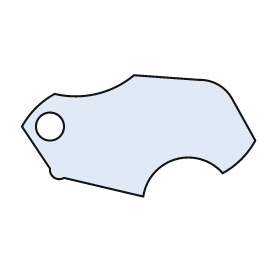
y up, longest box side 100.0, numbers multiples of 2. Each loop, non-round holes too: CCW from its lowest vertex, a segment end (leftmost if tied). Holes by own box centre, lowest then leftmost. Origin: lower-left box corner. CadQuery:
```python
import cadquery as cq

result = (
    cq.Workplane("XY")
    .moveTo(52.0, 0.0)
    .threePointArc((66.0, 16.0), (86.0, 10.0))
    .threePointArc((94.0, 16.0), (100.0, 24.0))
    .lineTo(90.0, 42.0)
    .threePointArc((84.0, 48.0), (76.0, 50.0))
    .lineTo(48.0, 52.0)
    .threePointArc((32.0, 44.0), (14.0, 44.0))
    .threePointArc((6.0, 38.0), (0.0, 30.0))
    .lineTo(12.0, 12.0)
    .threePointArc((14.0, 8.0), (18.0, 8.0))
    .close()
    .moveTo(12.0, 30.0)
    .circle(6.0)
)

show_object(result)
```